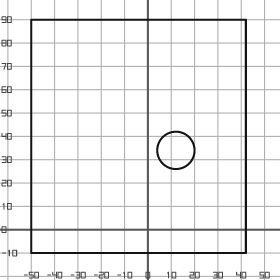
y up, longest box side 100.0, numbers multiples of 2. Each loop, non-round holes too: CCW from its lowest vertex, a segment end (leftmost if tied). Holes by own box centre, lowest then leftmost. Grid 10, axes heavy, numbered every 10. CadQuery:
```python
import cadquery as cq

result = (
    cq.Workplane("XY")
    .moveTo(-50.0, -10.0)
    .lineTo(42.0, -10.0)
    .lineTo(42.0, 90.0)
    .lineTo(-50.0, 90.0)
    .close()
    .moveTo(12.0, 34.0)
    .circle(8.0)
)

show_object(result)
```